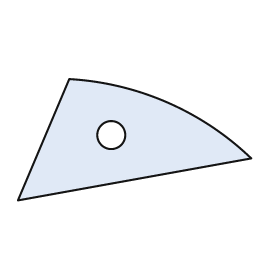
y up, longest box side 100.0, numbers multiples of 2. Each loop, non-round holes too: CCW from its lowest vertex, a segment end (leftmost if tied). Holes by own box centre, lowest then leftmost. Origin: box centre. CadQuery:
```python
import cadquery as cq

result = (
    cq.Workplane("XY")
    .moveTo(-50.0, -26.0)
    .lineTo(50.0, -8.0)
    .threePointArc((14.0, 16.0), (-28.0, 26.0))
    .close()
    .moveTo(-10.0, 2.0)
    .circle(6.0)
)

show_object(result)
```